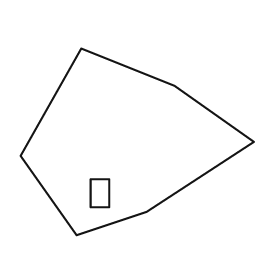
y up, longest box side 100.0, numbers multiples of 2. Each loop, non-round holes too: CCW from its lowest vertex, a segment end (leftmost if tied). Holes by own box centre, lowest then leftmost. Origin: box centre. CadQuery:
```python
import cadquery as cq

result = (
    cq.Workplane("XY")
    .moveTo(-26.0, -40.0)
    .lineTo(4.0, -30.0)
    .lineTo(50.0, 0.0)
    .lineTo(16.0, 24.0)
    .lineTo(-24.0, 40.0)
    .lineTo(-50.0, -6.0)
    .close()
    .moveTo(-20.0, -28.0)
    .lineTo(-12.0, -28.0)
    .lineTo(-12.0, -16.0)
    .lineTo(-20.0, -16.0)
    .close()
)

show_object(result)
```